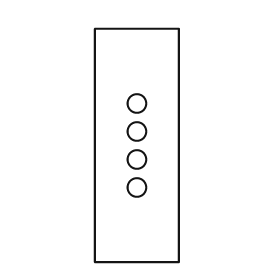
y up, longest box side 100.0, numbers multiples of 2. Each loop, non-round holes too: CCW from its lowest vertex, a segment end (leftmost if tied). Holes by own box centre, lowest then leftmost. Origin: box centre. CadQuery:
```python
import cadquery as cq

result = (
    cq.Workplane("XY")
    .moveTo(-18.0, -50.0)
    .lineTo(18.0, -50.0)
    .lineTo(18.0, 50.0)
    .lineTo(-18.0, 50.0)
    .close()
    .moveTo(0.0, -18.0)
    .circle(4.0)
    .moveTo(0.0, -6.0)
    .circle(4.0)
    .moveTo(0.0, 6.0)
    .circle(4.0)
    .moveTo(0.0, 18.0)
    .circle(4.0)
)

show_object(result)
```